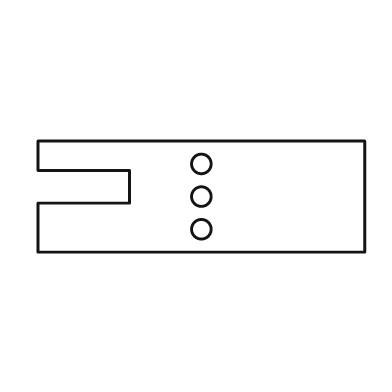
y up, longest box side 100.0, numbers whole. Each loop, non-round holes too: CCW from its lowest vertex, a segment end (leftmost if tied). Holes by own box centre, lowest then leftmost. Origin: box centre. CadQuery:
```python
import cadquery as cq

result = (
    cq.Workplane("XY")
    .moveTo(-50.0, -17.0)
    .lineTo(50.0, -17.0)
    .lineTo(50.0, 17.0)
    .lineTo(-50.0, 17.0)
    .lineTo(-50.0, 8.0)
    .lineTo(-22.0, 8.0)
    .lineTo(-22.0, -2.0)
    .lineTo(-50.0, -2.0)
    .close()
    .moveTo(0.0, -10.0)
    .circle(3.0)
    .moveTo(0.0, 0.0)
    .circle(3.0)
    .moveTo(0.0, 10.0)
    .circle(3.0)
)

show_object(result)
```